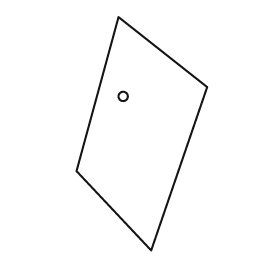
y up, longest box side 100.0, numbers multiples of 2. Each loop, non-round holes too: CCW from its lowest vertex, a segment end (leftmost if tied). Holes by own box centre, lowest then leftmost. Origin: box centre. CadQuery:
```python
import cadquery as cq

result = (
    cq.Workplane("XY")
    .moveTo(4.0, -50.0)
    .lineTo(28.0, 20.0)
    .lineTo(-10.0, 50.0)
    .lineTo(-28.0, -16.0)
    .close()
    .moveTo(-8.0, 16.0)
    .circle(2.0)
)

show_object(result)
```